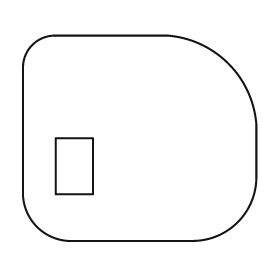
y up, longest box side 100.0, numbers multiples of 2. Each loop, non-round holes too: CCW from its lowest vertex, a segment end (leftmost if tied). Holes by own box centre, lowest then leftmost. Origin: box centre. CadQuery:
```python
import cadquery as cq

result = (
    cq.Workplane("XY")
    .moveTo(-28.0, -44.0)
    .lineTo(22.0, -44.0)
    .threePointArc((42.0, -36.0), (50.0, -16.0))
    .lineTo(50.0, 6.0)
    .threePointArc((38.0, 32.0), (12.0, 44.0))
    .lineTo(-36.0, 44.0)
    .threePointArc((-46.0, 40.0), (-50.0, 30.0))
    .lineTo(-50.0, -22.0)
    .threePointArc((-44.0, -38.0), (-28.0, -44.0))
    .close()
    .moveTo(-36.0, -24.0)
    .lineTo(-20.0, -24.0)
    .lineTo(-20.0, 0.0)
    .lineTo(-36.0, 0.0)
    .close()
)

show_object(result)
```